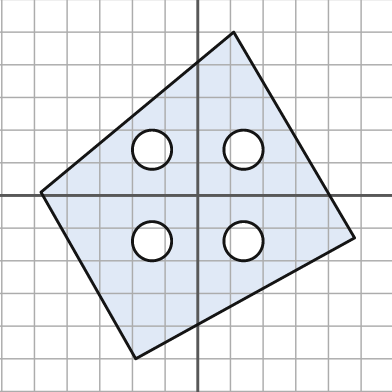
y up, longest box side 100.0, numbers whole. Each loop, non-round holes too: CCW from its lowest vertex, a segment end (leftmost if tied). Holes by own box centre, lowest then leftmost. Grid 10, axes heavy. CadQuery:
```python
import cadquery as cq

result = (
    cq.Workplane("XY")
    .moveTo(-19.0, -50.0)
    .lineTo(48.0, -13.0)
    .lineTo(11.0, 50.0)
    .lineTo(-48.0, 1.0)
    .close()
    .moveTo(-14.0, -14.0)
    .circle(6.0)
    .moveTo(14.0, -14.0)
    .circle(6.0)
    .moveTo(-14.0, 14.0)
    .circle(6.0)
    .moveTo(14.0, 14.0)
    .circle(6.0)
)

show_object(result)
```